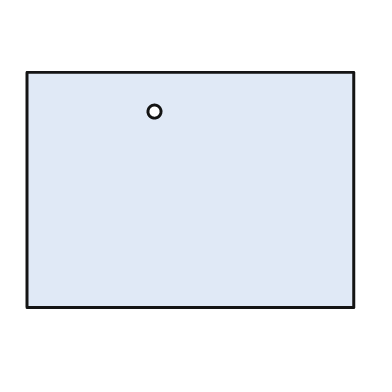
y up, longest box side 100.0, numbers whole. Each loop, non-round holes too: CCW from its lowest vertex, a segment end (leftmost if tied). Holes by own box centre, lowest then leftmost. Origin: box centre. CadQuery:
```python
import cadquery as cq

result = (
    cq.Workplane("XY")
    .moveTo(-50.0, -36.0)
    .lineTo(50.0, -36.0)
    .lineTo(50.0, 36.0)
    .lineTo(-50.0, 36.0)
    .close()
    .moveTo(-11.0, 24.0)
    .circle(2.0)
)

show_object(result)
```